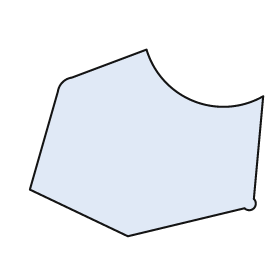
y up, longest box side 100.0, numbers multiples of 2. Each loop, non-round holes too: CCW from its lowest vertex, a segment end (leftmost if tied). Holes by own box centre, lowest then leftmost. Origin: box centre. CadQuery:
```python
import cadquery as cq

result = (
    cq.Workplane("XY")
    .moveTo(-8.0, -40.0)
    .lineTo(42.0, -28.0)
    .threePointArc((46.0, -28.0), (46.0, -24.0))
    .lineTo(50.0, 20.0)
    .threePointArc((20.0, 18.0), (0.0, 40.0))
    .lineTo(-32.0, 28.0)
    .threePointArc((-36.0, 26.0), (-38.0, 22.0))
    .lineTo(-50.0, -20.0)
    .close()
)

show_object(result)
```